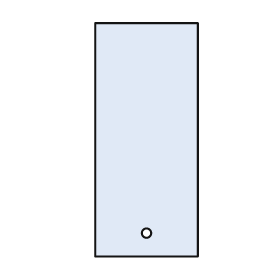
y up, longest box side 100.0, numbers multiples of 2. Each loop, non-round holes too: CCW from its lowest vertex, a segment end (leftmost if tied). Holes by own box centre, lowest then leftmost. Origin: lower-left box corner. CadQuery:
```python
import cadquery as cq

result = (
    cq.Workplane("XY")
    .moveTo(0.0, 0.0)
    .lineTo(44.0, 0.0)
    .lineTo(44.0, 100.0)
    .lineTo(0.0, 100.0)
    .close()
    .moveTo(22.0, 10.0)
    .circle(2.0)
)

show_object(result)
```